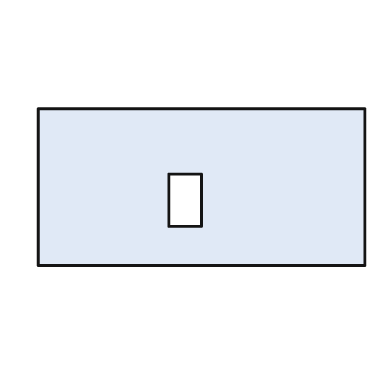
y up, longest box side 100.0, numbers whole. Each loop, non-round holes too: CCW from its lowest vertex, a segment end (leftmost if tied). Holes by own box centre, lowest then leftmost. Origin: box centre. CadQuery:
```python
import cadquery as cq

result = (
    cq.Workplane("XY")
    .moveTo(-50.0, -24.0)
    .lineTo(50.0, -24.0)
    .lineTo(50.0, 24.0)
    .lineTo(-50.0, 24.0)
    .close()
    .moveTo(-10.0, -12.0)
    .lineTo(0.0, -12.0)
    .lineTo(0.0, 4.0)
    .lineTo(-10.0, 4.0)
    .close()
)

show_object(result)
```